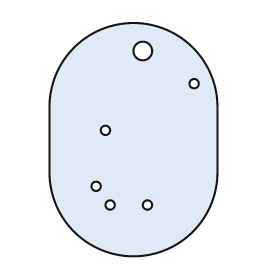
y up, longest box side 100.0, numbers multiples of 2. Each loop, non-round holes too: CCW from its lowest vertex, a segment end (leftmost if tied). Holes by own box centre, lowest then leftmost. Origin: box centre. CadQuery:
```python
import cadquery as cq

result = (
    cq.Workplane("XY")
    .moveTo(-36.0, -14.0)
    .threePointArc((0.0, -50.0), (36.0, -14.0))
    .lineTo(36.0, 14.0)
    .threePointArc((0.0, 50.0), (-36.0, 14.0))
    .close()
    .moveTo(-10.0, -28.0)
    .circle(2.0)
    .moveTo(6.0, -28.0)
    .circle(2.0)
    .moveTo(-16.0, -20.0)
    .circle(2.0)
    .moveTo(-12.0, 4.0)
    .circle(2.0)
    .moveTo(26.0, 24.0)
    .circle(2.0)
    .moveTo(4.0, 38.0)
    .circle(4.0)
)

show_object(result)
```